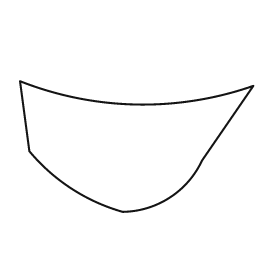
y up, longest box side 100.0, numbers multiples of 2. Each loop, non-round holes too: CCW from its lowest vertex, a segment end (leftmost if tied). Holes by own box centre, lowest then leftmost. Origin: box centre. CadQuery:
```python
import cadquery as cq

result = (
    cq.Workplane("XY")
    .moveTo(-6.0, -28.0)
    .threePointArc((14.0, -22.0), (28.0, -6.0))
    .lineTo(50.0, 26.0)
    .threePointArc((0.0, 18.0), (-50.0, 28.0))
    .lineTo(-46.0, -2.0)
    .threePointArc((-28.0, -18.0), (-6.0, -28.0))
    .close()
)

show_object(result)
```